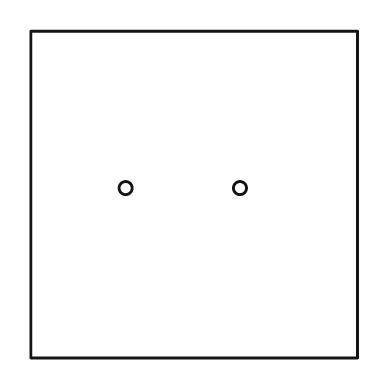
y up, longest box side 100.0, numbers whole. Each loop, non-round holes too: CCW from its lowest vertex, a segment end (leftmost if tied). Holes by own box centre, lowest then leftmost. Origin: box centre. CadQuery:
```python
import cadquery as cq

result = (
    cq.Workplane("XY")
    .moveTo(-50.0, -50.0)
    .lineTo(50.0, -50.0)
    .lineTo(50.0, 50.0)
    .lineTo(-50.0, 50.0)
    .close()
    .moveTo(-21.0, 2.0)
    .circle(2.0)
    .moveTo(14.0, 2.0)
    .circle(2.0)
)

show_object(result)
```